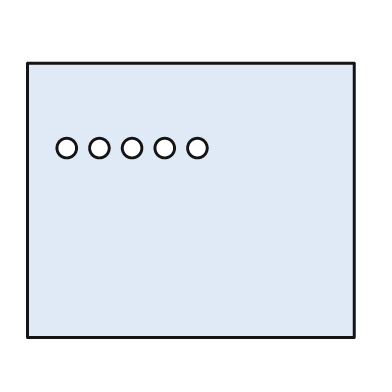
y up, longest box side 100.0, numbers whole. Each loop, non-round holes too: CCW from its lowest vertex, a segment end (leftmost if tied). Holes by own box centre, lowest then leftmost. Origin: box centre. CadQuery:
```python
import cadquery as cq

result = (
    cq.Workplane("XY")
    .moveTo(-50.0, -42.0)
    .lineTo(50.0, -42.0)
    .lineTo(50.0, 42.0)
    .lineTo(-50.0, 42.0)
    .close()
    .moveTo(-38.0, 16.0)
    .circle(3.0)
    .moveTo(-28.0, 16.0)
    .circle(3.0)
    .moveTo(-18.0, 16.0)
    .circle(3.0)
    .moveTo(-8.0, 16.0)
    .circle(3.0)
    .moveTo(2.0, 16.0)
    .circle(3.0)
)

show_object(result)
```